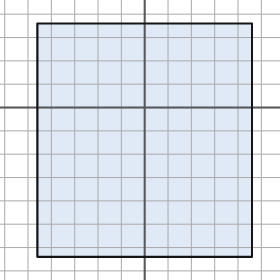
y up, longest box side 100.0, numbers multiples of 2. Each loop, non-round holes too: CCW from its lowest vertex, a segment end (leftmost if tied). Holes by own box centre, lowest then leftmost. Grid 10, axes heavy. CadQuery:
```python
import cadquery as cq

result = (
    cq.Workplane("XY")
    .moveTo(-46.0, -64.0)
    .lineTo(46.0, -64.0)
    .lineTo(46.0, 36.0)
    .lineTo(-46.0, 36.0)
    .close()
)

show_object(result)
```